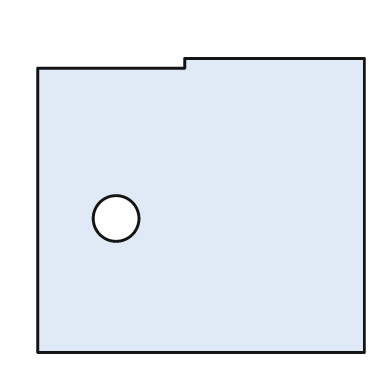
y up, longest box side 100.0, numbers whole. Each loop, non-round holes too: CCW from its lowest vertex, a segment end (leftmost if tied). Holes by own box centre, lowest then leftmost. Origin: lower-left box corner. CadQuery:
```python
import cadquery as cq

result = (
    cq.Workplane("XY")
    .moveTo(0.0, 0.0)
    .lineTo(100.0, 0.0)
    .lineTo(100.0, 90.0)
    .lineTo(45.0, 90.0)
    .lineTo(45.0, 87.0)
    .lineTo(0.0, 87.0)
    .close()
    .moveTo(24.0, 41.0)
    .circle(7.0)
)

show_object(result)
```